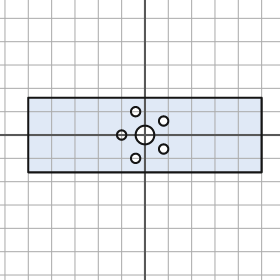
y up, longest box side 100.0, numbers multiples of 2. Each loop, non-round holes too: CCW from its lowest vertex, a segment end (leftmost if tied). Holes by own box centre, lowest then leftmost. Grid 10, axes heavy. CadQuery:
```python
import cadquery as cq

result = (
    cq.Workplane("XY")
    .moveTo(-50.0, -16.0)
    .lineTo(50.0, -16.0)
    .lineTo(50.0, 16.0)
    .lineTo(-50.0, 16.0)
    .close()
    .moveTo(-4.0, -10.0)
    .circle(2.0)
    .moveTo(8.0, -6.0)
    .circle(2.0)
    .moveTo(-10.0, 0.0)
    .circle(2.0)
    .moveTo(0.0, 0.0)
    .circle(4.0)
    .moveTo(8.0, 6.0)
    .circle(2.0)
    .moveTo(-4.0, 10.0)
    .circle(2.0)
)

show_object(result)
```